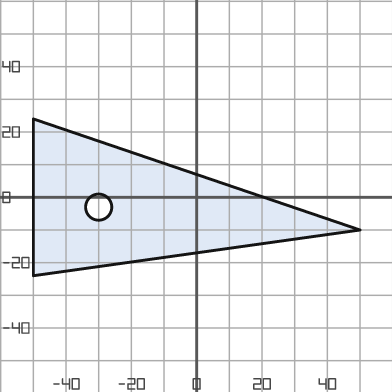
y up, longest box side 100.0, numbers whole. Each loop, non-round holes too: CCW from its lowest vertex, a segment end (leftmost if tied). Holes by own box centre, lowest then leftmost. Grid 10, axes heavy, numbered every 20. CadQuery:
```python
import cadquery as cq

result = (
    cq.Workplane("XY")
    .moveTo(-50.0, -24.0)
    .lineTo(50.0, -10.0)
    .lineTo(-50.0, 24.0)
    .close()
    .moveTo(-30.0, -3.0)
    .circle(4.0)
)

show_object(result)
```